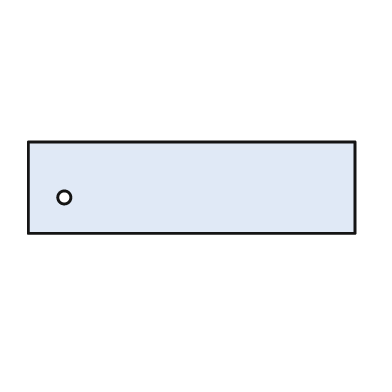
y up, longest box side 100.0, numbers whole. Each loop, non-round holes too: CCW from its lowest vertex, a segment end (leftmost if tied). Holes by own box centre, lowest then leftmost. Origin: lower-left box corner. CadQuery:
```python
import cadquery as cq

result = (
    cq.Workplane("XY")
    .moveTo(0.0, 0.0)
    .lineTo(100.0, 0.0)
    .lineTo(100.0, 28.0)
    .lineTo(0.0, 28.0)
    .close()
    .moveTo(11.0, 11.0)
    .circle(2.0)
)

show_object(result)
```